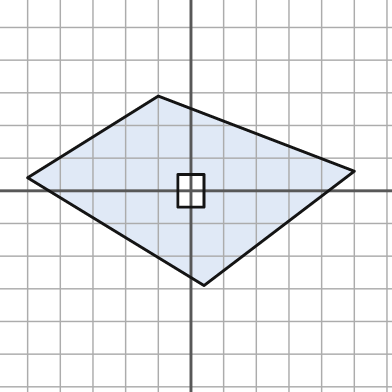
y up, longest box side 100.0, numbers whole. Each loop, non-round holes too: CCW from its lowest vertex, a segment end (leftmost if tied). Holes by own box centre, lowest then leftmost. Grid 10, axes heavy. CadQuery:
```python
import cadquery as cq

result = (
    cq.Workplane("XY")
    .moveTo(4.0, -29.0)
    .lineTo(50.0, 6.0)
    .lineTo(-10.0, 29.0)
    .lineTo(-50.0, 4.0)
    .close()
    .moveTo(-4.0, -5.0)
    .lineTo(4.0, -5.0)
    .lineTo(4.0, 5.0)
    .lineTo(-4.0, 5.0)
    .close()
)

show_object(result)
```